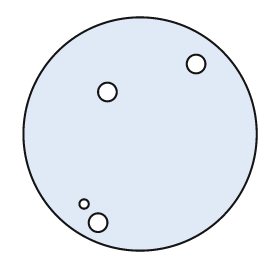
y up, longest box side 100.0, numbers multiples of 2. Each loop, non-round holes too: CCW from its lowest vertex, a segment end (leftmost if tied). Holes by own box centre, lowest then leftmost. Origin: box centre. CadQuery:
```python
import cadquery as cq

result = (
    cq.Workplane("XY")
    .moveTo(0.0, 0.0)
    .circle(50.0)
    .moveTo(-18.0, -38.0)
    .circle(4.0)
    .moveTo(-24.0, -30.0)
    .circle(2.0)
    .moveTo(-14.0, 18.0)
    .circle(4.0)
    .moveTo(24.0, 30.0)
    .circle(4.0)
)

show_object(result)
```